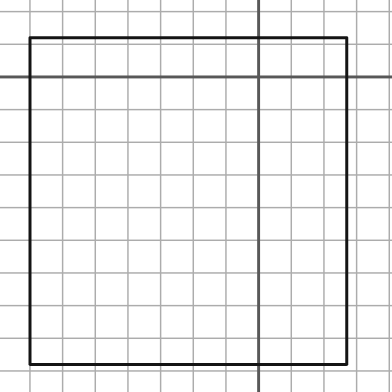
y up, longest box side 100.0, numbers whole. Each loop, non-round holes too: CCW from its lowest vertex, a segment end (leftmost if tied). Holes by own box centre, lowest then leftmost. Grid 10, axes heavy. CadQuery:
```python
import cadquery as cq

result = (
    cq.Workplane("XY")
    .moveTo(-70.0, -88.0)
    .lineTo(27.0, -88.0)
    .lineTo(27.0, 12.0)
    .lineTo(-70.0, 12.0)
    .close()
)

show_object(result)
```